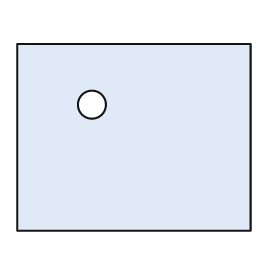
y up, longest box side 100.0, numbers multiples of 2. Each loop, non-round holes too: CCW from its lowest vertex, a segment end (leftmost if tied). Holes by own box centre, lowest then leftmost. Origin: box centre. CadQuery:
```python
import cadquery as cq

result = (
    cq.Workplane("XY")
    .moveTo(-50.0, -40.0)
    .lineTo(50.0, -40.0)
    .lineTo(50.0, 40.0)
    .lineTo(-50.0, 40.0)
    .close()
    .moveTo(-18.0, 14.0)
    .circle(6.0)
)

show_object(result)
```